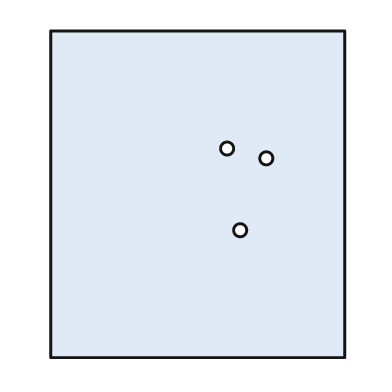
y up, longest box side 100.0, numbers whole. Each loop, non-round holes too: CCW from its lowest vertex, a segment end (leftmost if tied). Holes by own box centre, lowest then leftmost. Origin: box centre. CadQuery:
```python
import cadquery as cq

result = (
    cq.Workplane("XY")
    .moveTo(-45.0, -50.0)
    .lineTo(45.0, -50.0)
    .lineTo(45.0, 50.0)
    .lineTo(-45.0, 50.0)
    .close()
    .moveTo(13.0, -11.0)
    .circle(2.0)
    .moveTo(21.0, 11.0)
    .circle(2.0)
    .moveTo(9.0, 14.0)
    .circle(2.0)
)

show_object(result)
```